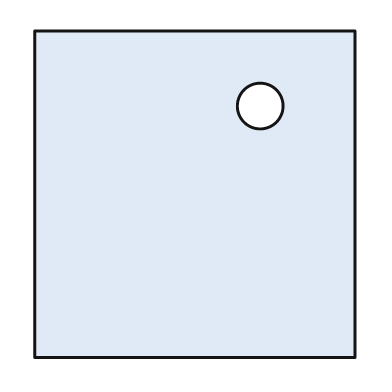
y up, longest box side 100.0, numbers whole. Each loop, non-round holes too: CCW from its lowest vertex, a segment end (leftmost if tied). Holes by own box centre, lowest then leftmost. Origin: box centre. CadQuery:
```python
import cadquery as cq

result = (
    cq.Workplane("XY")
    .moveTo(-49.0, -50.0)
    .lineTo(49.0, -50.0)
    .lineTo(49.0, 50.0)
    .lineTo(-49.0, 50.0)
    .close()
    .moveTo(20.0, 27.0)
    .circle(7.0)
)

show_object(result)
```